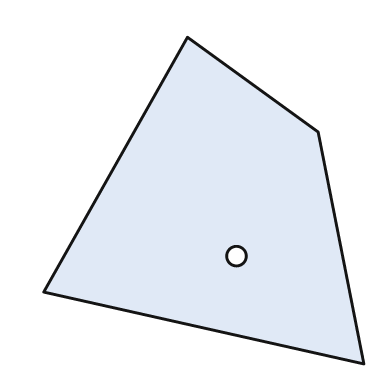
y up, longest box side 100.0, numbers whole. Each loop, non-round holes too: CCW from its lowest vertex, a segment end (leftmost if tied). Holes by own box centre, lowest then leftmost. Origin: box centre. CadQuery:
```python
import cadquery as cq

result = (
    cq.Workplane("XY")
    .moveTo(49.0, -50.0)
    .lineTo(35.0, 21.0)
    .lineTo(-5.0, 50.0)
    .lineTo(-49.0, -28.0)
    .close()
    .moveTo(10.0, -17.0)
    .circle(3.0)
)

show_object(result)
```